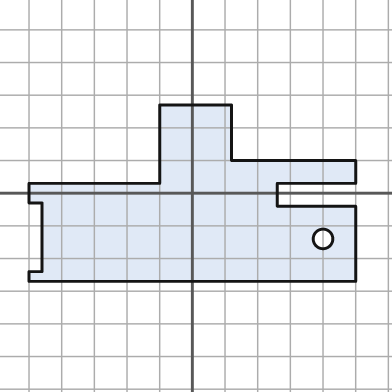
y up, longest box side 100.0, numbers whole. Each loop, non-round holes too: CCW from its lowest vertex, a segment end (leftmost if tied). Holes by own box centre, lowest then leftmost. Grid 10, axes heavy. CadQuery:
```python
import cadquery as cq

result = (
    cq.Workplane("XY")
    .moveTo(-50.0, -27.0)
    .lineTo(50.0, -27.0)
    .lineTo(50.0, -4.0)
    .lineTo(26.0, -4.0)
    .lineTo(26.0, 3.0)
    .lineTo(50.0, 3.0)
    .lineTo(50.0, 10.0)
    .lineTo(12.0, 10.0)
    .lineTo(12.0, 27.0)
    .lineTo(-10.0, 27.0)
    .lineTo(-10.0, 3.0)
    .lineTo(-50.0, 3.0)
    .lineTo(-50.0, -3.0)
    .lineTo(-46.0, -3.0)
    .lineTo(-46.0, -24.0)
    .lineTo(-50.0, -24.0)
    .close()
    .moveTo(40.0, -14.0)
    .circle(3.0)
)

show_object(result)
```